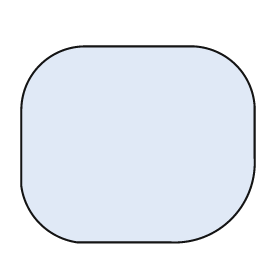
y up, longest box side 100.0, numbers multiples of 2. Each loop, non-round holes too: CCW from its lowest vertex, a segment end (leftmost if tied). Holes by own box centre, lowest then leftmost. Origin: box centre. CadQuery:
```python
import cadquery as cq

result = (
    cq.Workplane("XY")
    .moveTo(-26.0, -42.0)
    .lineTo(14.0, -42.0)
    .threePointArc((40.0, -32.0), (50.0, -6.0))
    .lineTo(50.0, 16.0)
    .threePointArc((42.0, 34.0), (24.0, 42.0))
    .lineTo(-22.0, 42.0)
    .threePointArc((-42.0, 34.0), (-50.0, 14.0))
    .lineTo(-50.0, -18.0)
    .threePointArc((-42.0, -34.0), (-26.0, -42.0))
    .close()
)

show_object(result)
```